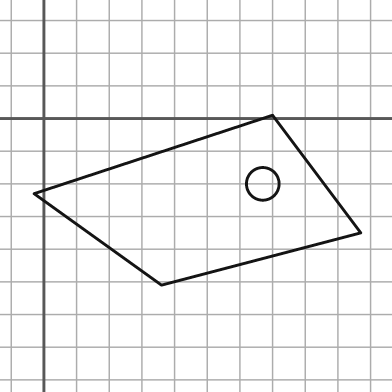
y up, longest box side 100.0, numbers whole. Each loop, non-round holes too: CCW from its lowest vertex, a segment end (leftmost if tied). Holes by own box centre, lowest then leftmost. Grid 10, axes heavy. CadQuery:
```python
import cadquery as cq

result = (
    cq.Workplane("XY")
    .moveTo(36.0, -51.0)
    .lineTo(97.0, -35.0)
    .lineTo(70.0, 1.0)
    .lineTo(-3.0, -23.0)
    .close()
    .moveTo(67.0, -20.0)
    .circle(5.0)
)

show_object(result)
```